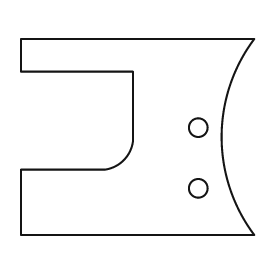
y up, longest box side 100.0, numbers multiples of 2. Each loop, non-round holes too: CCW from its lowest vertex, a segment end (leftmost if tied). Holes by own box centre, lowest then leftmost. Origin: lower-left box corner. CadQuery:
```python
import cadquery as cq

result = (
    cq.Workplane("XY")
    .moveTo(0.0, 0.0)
    .lineTo(100.0, 0.0)
    .threePointArc((86.0, 42.0), (100.0, 84.0))
    .lineTo(0.0, 84.0)
    .lineTo(0.0, 70.0)
    .lineTo(48.0, 70.0)
    .lineTo(48.0, 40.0)
    .threePointArc((44.0, 32.0), (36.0, 28.0))
    .lineTo(0.0, 28.0)
    .close()
    .moveTo(76.0, 20.0)
    .circle(4.0)
    .moveTo(76.0, 46.0)
    .circle(4.0)
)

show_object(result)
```